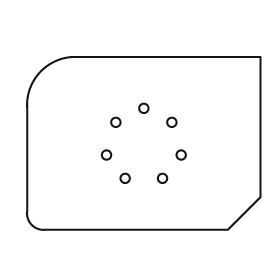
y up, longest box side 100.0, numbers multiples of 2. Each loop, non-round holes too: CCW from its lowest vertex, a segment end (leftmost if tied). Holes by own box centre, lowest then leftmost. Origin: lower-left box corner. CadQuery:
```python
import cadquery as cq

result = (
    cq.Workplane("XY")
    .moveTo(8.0, 0.0)
    .lineTo(86.0, 0.0)
    .lineTo(100.0, 14.0)
    .lineTo(100.0, 74.0)
    .lineTo(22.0, 74.0)
    .threePointArc((6.0, 68.0), (0.0, 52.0))
    .lineTo(0.0, 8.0)
    .threePointArc((2.0, 2.0), (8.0, 0.0))
    .close()
    .moveTo(42.0, 22.0)
    .circle(2.0)
    .moveTo(58.0, 22.0)
    .circle(2.0)
    .moveTo(34.0, 32.0)
    .circle(2.0)
    .moveTo(66.0, 32.0)
    .circle(2.0)
    .moveTo(38.0, 46.0)
    .circle(2.0)
    .moveTo(62.0, 46.0)
    .circle(2.0)
    .moveTo(50.0, 52.0)
    .circle(2.0)
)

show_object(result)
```